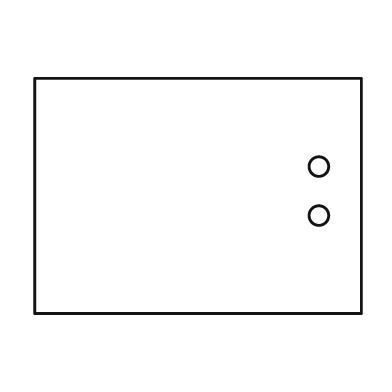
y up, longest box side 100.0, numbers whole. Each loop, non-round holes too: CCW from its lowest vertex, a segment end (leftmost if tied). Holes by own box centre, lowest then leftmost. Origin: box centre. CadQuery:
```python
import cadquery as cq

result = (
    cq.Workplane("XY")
    .moveTo(-50.0, -36.0)
    .lineTo(50.0, -36.0)
    .lineTo(50.0, 36.0)
    .lineTo(-50.0, 36.0)
    .close()
    .moveTo(37.0, -6.0)
    .circle(3.0)
    .moveTo(37.0, 9.0)
    .circle(3.0)
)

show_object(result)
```